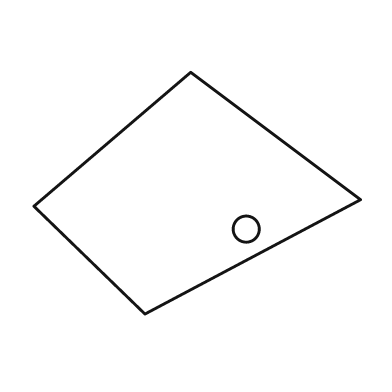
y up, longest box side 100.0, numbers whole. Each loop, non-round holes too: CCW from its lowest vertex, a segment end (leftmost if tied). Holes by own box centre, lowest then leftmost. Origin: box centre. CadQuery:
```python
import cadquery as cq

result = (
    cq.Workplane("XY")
    .moveTo(-16.0, -37.0)
    .lineTo(50.0, -2.0)
    .lineTo(-2.0, 37.0)
    .lineTo(-50.0, -4.0)
    .close()
    .moveTo(15.0, -11.0)
    .circle(4.0)
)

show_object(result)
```